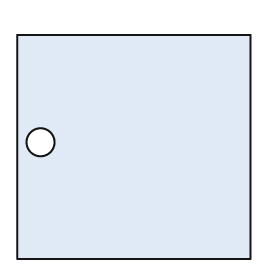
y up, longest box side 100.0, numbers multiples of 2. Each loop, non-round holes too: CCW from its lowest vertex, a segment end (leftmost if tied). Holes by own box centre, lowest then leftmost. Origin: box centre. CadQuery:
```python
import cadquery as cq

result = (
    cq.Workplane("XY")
    .moveTo(-50.0, -48.0)
    .lineTo(50.0, -48.0)
    .lineTo(50.0, 48.0)
    .lineTo(-50.0, 48.0)
    .close()
    .moveTo(-40.0, 2.0)
    .circle(6.0)
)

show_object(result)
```